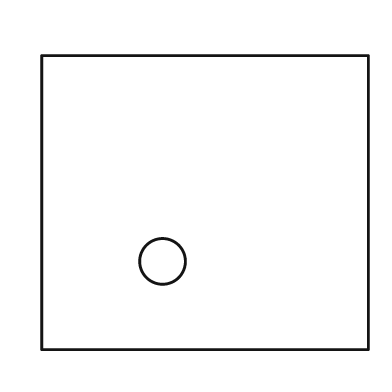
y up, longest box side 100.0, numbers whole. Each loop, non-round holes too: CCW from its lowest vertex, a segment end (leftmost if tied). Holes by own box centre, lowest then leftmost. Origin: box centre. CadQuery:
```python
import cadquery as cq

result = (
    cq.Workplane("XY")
    .moveTo(-50.0, -45.0)
    .lineTo(50.0, -45.0)
    .lineTo(50.0, 45.0)
    .lineTo(-50.0, 45.0)
    .close()
    .moveTo(-13.0, -18.0)
    .circle(7.0)
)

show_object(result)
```